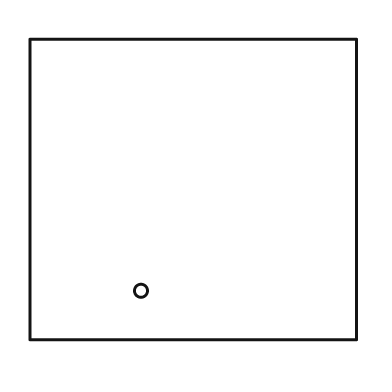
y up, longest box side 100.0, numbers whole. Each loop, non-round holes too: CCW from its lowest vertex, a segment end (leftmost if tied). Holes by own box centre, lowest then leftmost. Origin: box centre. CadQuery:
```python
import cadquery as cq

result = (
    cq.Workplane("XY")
    .moveTo(-50.0, -46.0)
    .lineTo(50.0, -46.0)
    .lineTo(50.0, 46.0)
    .lineTo(-50.0, 46.0)
    .close()
    .moveTo(-16.0, -31.0)
    .circle(2.0)
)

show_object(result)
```